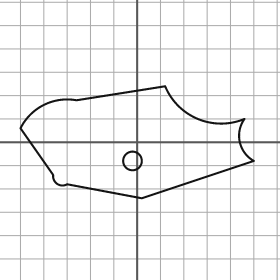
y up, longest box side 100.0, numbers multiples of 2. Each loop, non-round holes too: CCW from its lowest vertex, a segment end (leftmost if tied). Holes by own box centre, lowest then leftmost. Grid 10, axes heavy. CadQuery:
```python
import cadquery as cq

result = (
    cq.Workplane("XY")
    .moveTo(2.0, -24.0)
    .lineTo(50.0, -8.0)
    .threePointArc((44.0, 0.0), (46.0, 10.0))
    .threePointArc((26.0, 10.0), (12.0, 24.0))
    .lineTo(-26.0, 18.0)
    .threePointArc((-40.0, 16.0), (-50.0, 6.0))
    .lineTo(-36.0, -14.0)
    .threePointArc((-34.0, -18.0), (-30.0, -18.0))
    .close()
    .moveTo(-2.0, -8.0)
    .circle(4.0)
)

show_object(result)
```